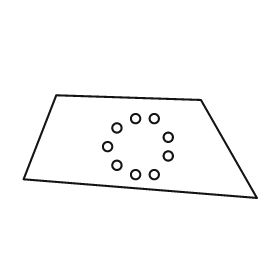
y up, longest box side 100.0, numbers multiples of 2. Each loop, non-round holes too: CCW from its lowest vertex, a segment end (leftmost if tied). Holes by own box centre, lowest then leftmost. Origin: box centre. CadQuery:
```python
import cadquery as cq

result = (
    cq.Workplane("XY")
    .moveTo(50.0, -22.0)
    .lineTo(26.0, 20.0)
    .lineTo(-36.0, 22.0)
    .lineTo(-50.0, -14.0)
    .close()
    .moveTo(-2.0, -12.0)
    .circle(2.0)
    .moveTo(6.0, -12.0)
    .circle(2.0)
    .moveTo(-10.0, -8.0)
    .circle(2.0)
    .moveTo(12.0, -4.0)
    .circle(2.0)
    .moveTo(-14.0, 0.0)
    .circle(2.0)
    .moveTo(12.0, 4.0)
    .circle(2.0)
    .moveTo(-10.0, 8.0)
    .circle(2.0)
    .moveTo(-2.0, 12.0)
    .circle(2.0)
    .moveTo(6.0, 12.0)
    .circle(2.0)
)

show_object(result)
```